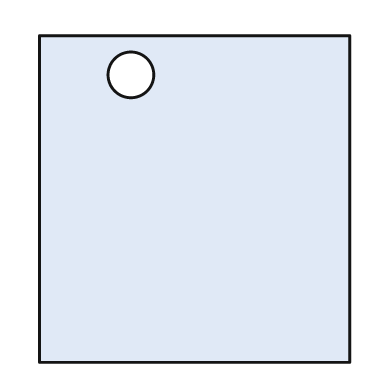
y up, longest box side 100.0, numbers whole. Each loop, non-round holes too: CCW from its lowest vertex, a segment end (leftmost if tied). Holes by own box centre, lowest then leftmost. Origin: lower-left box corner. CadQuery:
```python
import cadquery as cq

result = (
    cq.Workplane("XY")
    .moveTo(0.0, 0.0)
    .lineTo(95.0, 0.0)
    .lineTo(95.0, 100.0)
    .lineTo(0.0, 100.0)
    .close()
    .moveTo(28.0, 88.0)
    .circle(7.0)
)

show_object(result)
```